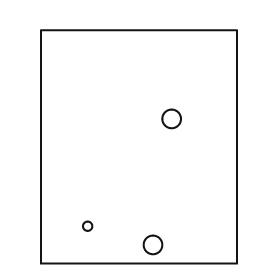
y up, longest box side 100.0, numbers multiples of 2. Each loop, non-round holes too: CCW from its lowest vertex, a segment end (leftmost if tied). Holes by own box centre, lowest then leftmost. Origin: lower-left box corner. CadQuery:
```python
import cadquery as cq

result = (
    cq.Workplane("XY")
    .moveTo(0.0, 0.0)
    .lineTo(84.0, 0.0)
    .lineTo(84.0, 100.0)
    .lineTo(0.0, 100.0)
    .close()
    .moveTo(48.0, 8.0)
    .circle(4.0)
    .moveTo(20.0, 16.0)
    .circle(2.0)
    .moveTo(56.0, 62.0)
    .circle(4.0)
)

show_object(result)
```